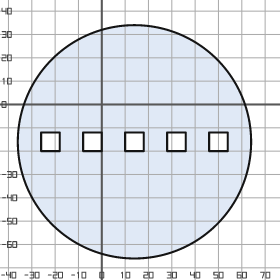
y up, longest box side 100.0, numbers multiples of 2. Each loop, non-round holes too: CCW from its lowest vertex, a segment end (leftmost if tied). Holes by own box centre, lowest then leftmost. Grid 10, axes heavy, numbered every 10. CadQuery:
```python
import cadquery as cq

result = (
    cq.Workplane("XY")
    .moveTo(14.0, -16.0)
    .circle(50.0)
    .moveTo(-26.0, -20.0)
    .lineTo(-18.0, -20.0)
    .lineTo(-18.0, -12.0)
    .lineTo(-26.0, -12.0)
    .close()
    .moveTo(-8.0, -20.0)
    .lineTo(0.0, -20.0)
    .lineTo(0.0, -12.0)
    .lineTo(-8.0, -12.0)
    .close()
    .moveTo(10.0, -20.0)
    .lineTo(18.0, -20.0)
    .lineTo(18.0, -12.0)
    .lineTo(10.0, -12.0)
    .close()
    .moveTo(28.0, -20.0)
    .lineTo(36.0, -20.0)
    .lineTo(36.0, -12.0)
    .lineTo(28.0, -12.0)
    .close()
    .moveTo(46.0, -20.0)
    .lineTo(54.0, -20.0)
    .lineTo(54.0, -12.0)
    .lineTo(46.0, -12.0)
    .close()
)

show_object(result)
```